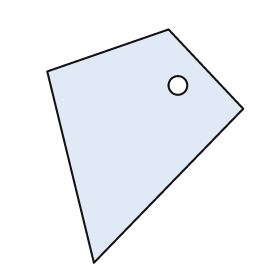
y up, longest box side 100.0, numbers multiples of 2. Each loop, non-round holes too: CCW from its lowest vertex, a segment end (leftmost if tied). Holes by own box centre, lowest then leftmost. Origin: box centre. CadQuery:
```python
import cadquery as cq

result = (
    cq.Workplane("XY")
    .moveTo(-22.0, -50.0)
    .lineTo(42.0, 16.0)
    .lineTo(10.0, 50.0)
    .lineTo(-42.0, 32.0)
    .close()
    .moveTo(14.0, 26.0)
    .circle(4.0)
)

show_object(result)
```